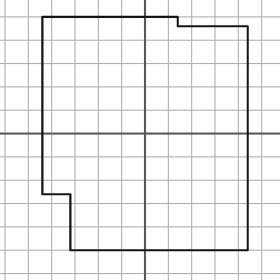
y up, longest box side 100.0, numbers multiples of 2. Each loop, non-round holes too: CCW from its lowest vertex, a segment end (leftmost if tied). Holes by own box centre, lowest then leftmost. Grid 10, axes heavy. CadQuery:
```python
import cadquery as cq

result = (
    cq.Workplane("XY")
    .moveTo(-32.0, -50.0)
    .lineTo(44.0, -50.0)
    .lineTo(44.0, 46.0)
    .lineTo(14.0, 46.0)
    .lineTo(14.0, 50.0)
    .lineTo(-44.0, 50.0)
    .lineTo(-44.0, -26.0)
    .lineTo(-32.0, -26.0)
    .close()
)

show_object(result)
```